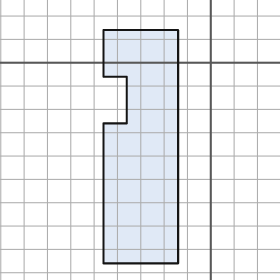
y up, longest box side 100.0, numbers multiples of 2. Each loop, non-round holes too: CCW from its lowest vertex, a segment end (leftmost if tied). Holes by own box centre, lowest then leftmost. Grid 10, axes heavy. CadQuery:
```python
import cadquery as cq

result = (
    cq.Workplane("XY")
    .moveTo(-46.0, -86.0)
    .lineTo(-14.0, -86.0)
    .lineTo(-14.0, 14.0)
    .lineTo(-46.0, 14.0)
    .lineTo(-46.0, -6.0)
    .lineTo(-36.0, -6.0)
    .lineTo(-36.0, -26.0)
    .lineTo(-46.0, -26.0)
    .close()
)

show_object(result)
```